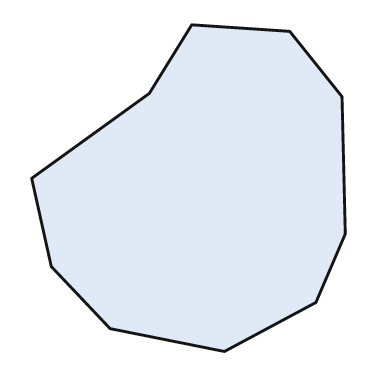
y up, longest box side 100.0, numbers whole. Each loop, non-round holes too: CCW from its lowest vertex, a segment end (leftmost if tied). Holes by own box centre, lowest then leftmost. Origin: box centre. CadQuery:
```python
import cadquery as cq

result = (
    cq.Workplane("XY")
    .moveTo(11.0, -50.0)
    .lineTo(39.0, -35.0)
    .lineTo(48.0, -14.0)
    .lineTo(47.0, 28.0)
    .lineTo(31.0, 48.0)
    .lineTo(1.0, 50.0)
    .lineTo(-12.0, 29.0)
    .lineTo(-48.0, 3.0)
    .lineTo(-42.0, -24.0)
    .lineTo(-24.0, -43.0)
    .close()
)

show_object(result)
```